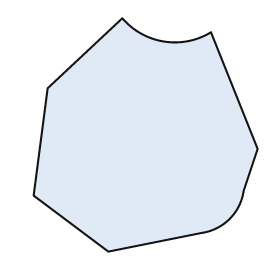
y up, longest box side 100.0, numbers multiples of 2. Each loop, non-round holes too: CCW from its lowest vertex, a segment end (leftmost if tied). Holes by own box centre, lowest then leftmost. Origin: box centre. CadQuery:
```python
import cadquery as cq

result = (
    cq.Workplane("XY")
    .moveTo(-16.0, -50.0)
    .lineTo(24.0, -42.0)
    .threePointArc((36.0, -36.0), (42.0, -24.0))
    .lineTo(48.0, -6.0)
    .lineTo(28.0, 44.0)
    .threePointArc((8.0, 40.0), (-10.0, 50.0))
    .lineTo(-42.0, 20.0)
    .lineTo(-48.0, -26.0)
    .close()
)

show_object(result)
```